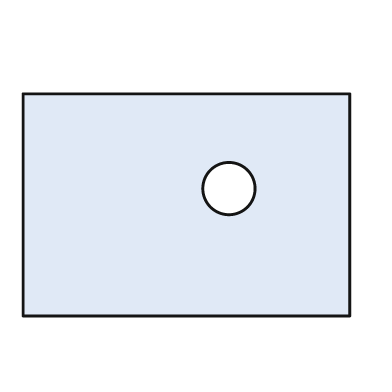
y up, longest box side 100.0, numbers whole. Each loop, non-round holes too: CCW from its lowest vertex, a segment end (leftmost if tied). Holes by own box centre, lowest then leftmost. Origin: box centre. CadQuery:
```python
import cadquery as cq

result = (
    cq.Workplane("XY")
    .moveTo(-50.0, -34.0)
    .lineTo(50.0, -34.0)
    .lineTo(50.0, 34.0)
    .lineTo(-50.0, 34.0)
    .close()
    .moveTo(13.0, 5.0)
    .circle(8.0)
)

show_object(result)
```